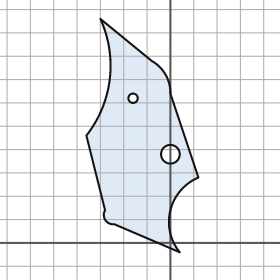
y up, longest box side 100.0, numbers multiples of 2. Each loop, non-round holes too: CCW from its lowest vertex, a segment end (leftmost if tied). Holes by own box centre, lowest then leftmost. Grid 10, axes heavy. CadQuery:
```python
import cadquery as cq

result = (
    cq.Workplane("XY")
    .moveTo(4.0, -4.0)
    .threePointArc((0.0, 14.0), (12.0, 28.0))
    .lineTo(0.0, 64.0)
    .threePointArc((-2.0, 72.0), (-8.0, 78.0))
    .lineTo(-30.0, 96.0)
    .threePointArc((-26.0, 70.0), (-36.0, 46.0))
    .lineTo(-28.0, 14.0)
    .threePointArc((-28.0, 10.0), (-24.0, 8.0))
    .close()
    .moveTo(0.0, 38.0)
    .circle(4.0)
    .moveTo(-16.0, 62.0)
    .circle(2.0)
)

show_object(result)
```